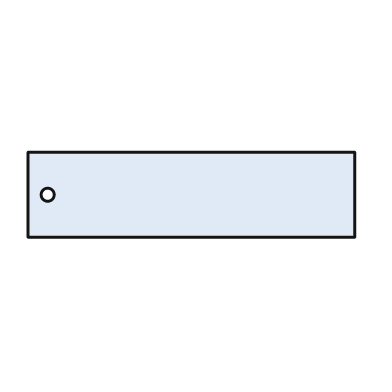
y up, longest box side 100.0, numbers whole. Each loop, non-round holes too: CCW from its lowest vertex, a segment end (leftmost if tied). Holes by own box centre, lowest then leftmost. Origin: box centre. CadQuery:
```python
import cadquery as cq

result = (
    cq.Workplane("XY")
    .moveTo(-50.0, -13.0)
    .lineTo(50.0, -13.0)
    .lineTo(50.0, 13.0)
    .lineTo(-50.0, 13.0)
    .close()
    .moveTo(-44.0, 0.0)
    .circle(2.0)
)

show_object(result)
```